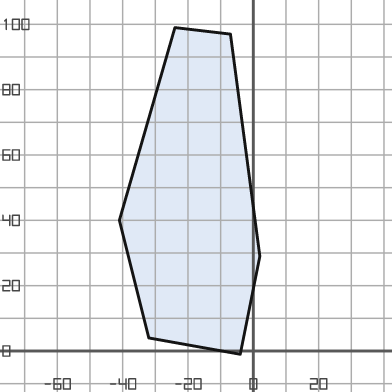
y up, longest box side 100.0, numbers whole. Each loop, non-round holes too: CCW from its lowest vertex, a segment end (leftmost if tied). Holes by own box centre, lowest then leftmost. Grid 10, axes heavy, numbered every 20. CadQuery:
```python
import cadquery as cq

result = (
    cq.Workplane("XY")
    .moveTo(-4.0, -1.0)
    .lineTo(2.0, 29.0)
    .lineTo(-7.0, 97.0)
    .lineTo(-24.0, 99.0)
    .lineTo(-41.0, 40.0)
    .lineTo(-32.0, 4.0)
    .close()
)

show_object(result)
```